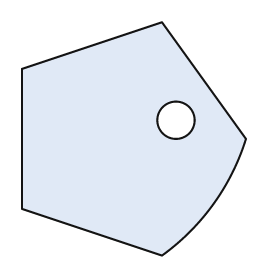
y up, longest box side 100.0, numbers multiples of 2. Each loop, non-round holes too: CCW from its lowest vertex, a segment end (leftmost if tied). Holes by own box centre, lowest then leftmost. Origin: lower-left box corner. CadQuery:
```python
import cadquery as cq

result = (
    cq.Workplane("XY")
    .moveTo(60.0, 0.0)
    .threePointArc((82.0, 22.0), (96.0, 50.0))
    .lineTo(60.0, 100.0)
    .lineTo(0.0, 80.0)
    .lineTo(0.0, 20.0)
    .close()
    .moveTo(66.0, 58.0)
    .circle(8.0)
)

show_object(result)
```